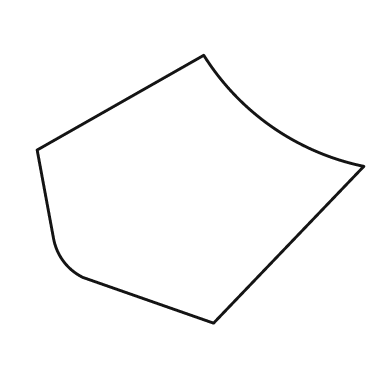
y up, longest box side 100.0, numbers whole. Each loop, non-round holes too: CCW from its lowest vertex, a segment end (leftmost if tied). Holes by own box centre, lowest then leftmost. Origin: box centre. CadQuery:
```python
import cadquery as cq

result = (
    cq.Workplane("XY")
    .moveTo(4.0, -41.0)
    .lineTo(50.0, 7.0)
    .threePointArc((22.0, 19.0), (1.0, 41.0))
    .lineTo(-50.0, 12.0)
    .lineTo(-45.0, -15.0)
    .threePointArc((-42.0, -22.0), (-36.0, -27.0))
    .close()
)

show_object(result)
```